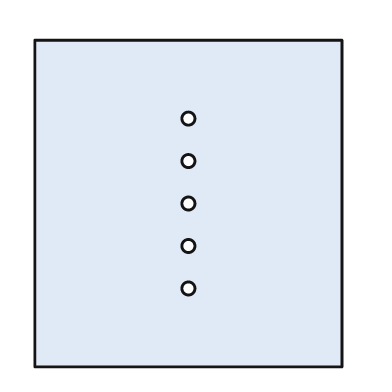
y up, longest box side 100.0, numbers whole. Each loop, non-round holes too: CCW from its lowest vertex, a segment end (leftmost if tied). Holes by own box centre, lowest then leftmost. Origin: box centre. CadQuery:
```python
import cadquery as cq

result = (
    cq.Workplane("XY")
    .moveTo(-47.0, -50.0)
    .lineTo(47.0, -50.0)
    .lineTo(47.0, 50.0)
    .lineTo(-47.0, 50.0)
    .close()
    .moveTo(0.0, -26.0)
    .circle(2.0)
    .moveTo(0.0, -13.0)
    .circle(2.0)
    .moveTo(0.0, 0.0)
    .circle(2.0)
    .moveTo(0.0, 13.0)
    .circle(2.0)
    .moveTo(0.0, 26.0)
    .circle(2.0)
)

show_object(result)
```